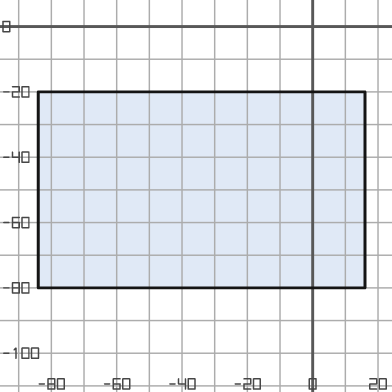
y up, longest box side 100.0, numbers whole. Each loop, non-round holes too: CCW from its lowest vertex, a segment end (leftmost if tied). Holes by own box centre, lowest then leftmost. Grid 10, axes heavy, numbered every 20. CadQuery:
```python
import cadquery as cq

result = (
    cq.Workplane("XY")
    .moveTo(-84.0, -80.0)
    .lineTo(16.0, -80.0)
    .lineTo(16.0, -20.0)
    .lineTo(-84.0, -20.0)
    .close()
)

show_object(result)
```